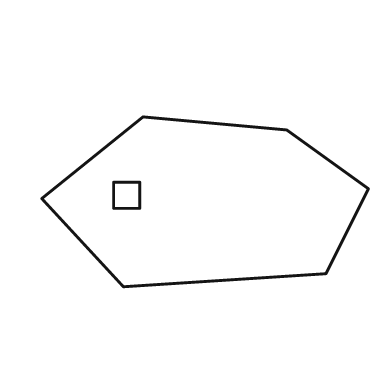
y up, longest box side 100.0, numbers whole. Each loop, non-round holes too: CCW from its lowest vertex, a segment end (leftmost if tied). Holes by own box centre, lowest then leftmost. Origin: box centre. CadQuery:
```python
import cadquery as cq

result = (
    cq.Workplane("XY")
    .moveTo(-25.0, -26.0)
    .lineTo(37.0, -22.0)
    .lineTo(50.0, 4.0)
    .lineTo(25.0, 22.0)
    .lineTo(-19.0, 26.0)
    .lineTo(-50.0, 1.0)
    .close()
    .moveTo(-28.0, -2.0)
    .lineTo(-20.0, -2.0)
    .lineTo(-20.0, 6.0)
    .lineTo(-28.0, 6.0)
    .close()
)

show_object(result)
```